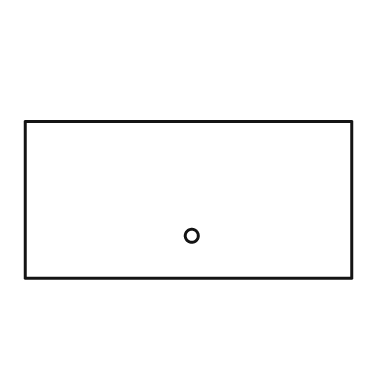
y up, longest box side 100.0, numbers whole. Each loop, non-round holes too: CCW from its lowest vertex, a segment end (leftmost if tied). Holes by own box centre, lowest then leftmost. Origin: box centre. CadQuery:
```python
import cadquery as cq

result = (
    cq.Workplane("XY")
    .moveTo(-50.0, -24.0)
    .lineTo(50.0, -24.0)
    .lineTo(50.0, 24.0)
    .lineTo(-50.0, 24.0)
    .close()
    .moveTo(1.0, -11.0)
    .circle(2.0)
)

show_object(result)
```